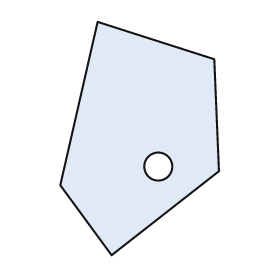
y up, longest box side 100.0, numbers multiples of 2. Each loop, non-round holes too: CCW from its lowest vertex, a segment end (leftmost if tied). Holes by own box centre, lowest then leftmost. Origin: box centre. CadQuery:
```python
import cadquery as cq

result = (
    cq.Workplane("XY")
    .moveTo(-12.0, -50.0)
    .lineTo(34.0, -14.0)
    .lineTo(32.0, 34.0)
    .lineTo(-18.0, 50.0)
    .lineTo(-34.0, -20.0)
    .close()
    .moveTo(8.0, -12.0)
    .circle(6.0)
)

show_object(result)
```